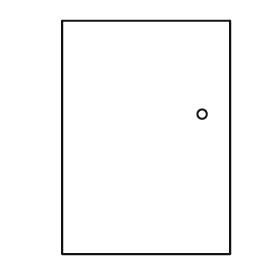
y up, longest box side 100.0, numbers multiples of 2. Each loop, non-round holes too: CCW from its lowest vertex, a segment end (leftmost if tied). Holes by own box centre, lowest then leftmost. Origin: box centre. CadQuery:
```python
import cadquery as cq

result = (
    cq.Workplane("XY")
    .moveTo(-36.0, -50.0)
    .lineTo(36.0, -50.0)
    .lineTo(36.0, 50.0)
    .lineTo(-36.0, 50.0)
    .close()
    .moveTo(24.0, 10.0)
    .circle(2.0)
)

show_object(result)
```